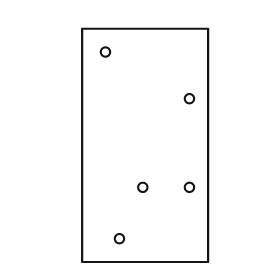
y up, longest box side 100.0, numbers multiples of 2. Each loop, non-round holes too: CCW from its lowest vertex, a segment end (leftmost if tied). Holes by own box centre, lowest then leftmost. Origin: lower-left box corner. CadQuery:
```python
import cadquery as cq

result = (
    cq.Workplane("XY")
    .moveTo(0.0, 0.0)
    .lineTo(54.0, 0.0)
    .lineTo(54.0, 100.0)
    .lineTo(0.0, 100.0)
    .close()
    .moveTo(16.0, 10.0)
    .circle(2.0)
    .moveTo(26.0, 32.0)
    .circle(2.0)
    .moveTo(46.0, 32.0)
    .circle(2.0)
    .moveTo(46.0, 70.0)
    .circle(2.0)
    .moveTo(10.0, 90.0)
    .circle(2.0)
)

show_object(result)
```